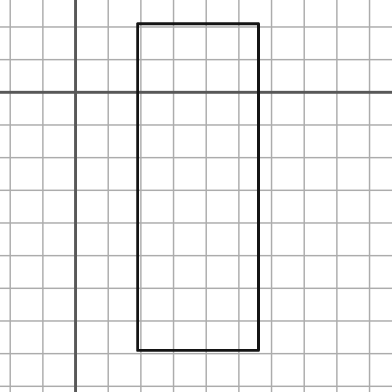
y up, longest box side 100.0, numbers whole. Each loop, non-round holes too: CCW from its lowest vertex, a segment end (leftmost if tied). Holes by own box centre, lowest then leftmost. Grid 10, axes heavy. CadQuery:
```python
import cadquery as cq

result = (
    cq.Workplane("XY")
    .moveTo(19.0, -79.0)
    .lineTo(56.0, -79.0)
    .lineTo(56.0, 21.0)
    .lineTo(19.0, 21.0)
    .close()
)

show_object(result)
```